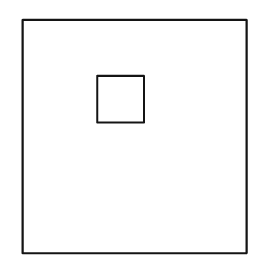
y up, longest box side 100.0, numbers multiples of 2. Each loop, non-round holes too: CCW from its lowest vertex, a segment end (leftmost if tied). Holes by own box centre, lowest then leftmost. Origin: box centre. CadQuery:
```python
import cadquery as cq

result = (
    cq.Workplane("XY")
    .moveTo(-48.0, -50.0)
    .lineTo(48.0, -50.0)
    .lineTo(48.0, 50.0)
    .lineTo(-48.0, 50.0)
    .close()
    .moveTo(-16.0, 6.0)
    .lineTo(4.0, 6.0)
    .lineTo(4.0, 26.0)
    .lineTo(-16.0, 26.0)
    .close()
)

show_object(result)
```